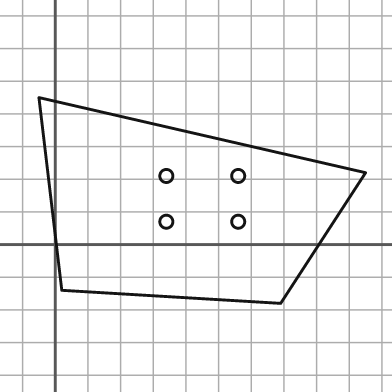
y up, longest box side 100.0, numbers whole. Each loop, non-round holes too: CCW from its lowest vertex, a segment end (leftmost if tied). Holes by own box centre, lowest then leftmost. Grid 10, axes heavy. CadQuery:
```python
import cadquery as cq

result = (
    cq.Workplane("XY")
    .moveTo(69.0, -18.0)
    .lineTo(95.0, 22.0)
    .lineTo(-5.0, 45.0)
    .lineTo(2.0, -14.0)
    .close()
    .moveTo(34.0, 7.0)
    .circle(2.0)
    .moveTo(56.0, 7.0)
    .circle(2.0)
    .moveTo(34.0, 21.0)
    .circle(2.0)
    .moveTo(56.0, 21.0)
    .circle(2.0)
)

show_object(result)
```